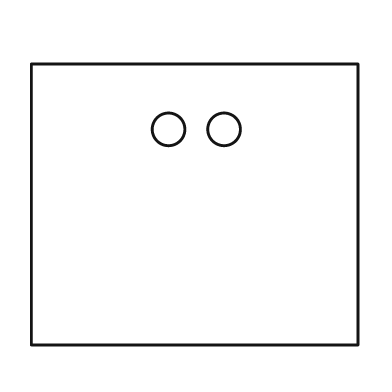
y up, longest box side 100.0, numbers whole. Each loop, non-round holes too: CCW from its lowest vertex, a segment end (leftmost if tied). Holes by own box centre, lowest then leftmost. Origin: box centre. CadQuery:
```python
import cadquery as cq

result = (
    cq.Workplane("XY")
    .moveTo(-50.0, -43.0)
    .lineTo(50.0, -43.0)
    .lineTo(50.0, 43.0)
    .lineTo(-50.0, 43.0)
    .close()
    .moveTo(-8.0, 23.0)
    .circle(5.0)
    .moveTo(9.0, 23.0)
    .circle(5.0)
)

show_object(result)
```